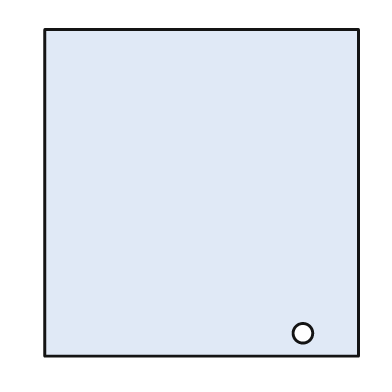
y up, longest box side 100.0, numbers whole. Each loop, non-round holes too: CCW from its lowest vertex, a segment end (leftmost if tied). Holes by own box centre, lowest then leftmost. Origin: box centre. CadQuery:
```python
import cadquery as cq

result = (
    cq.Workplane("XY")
    .moveTo(-48.0, -50.0)
    .lineTo(48.0, -50.0)
    .lineTo(48.0, 50.0)
    .lineTo(-48.0, 50.0)
    .close()
    .moveTo(31.0, -43.0)
    .circle(3.0)
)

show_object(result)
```